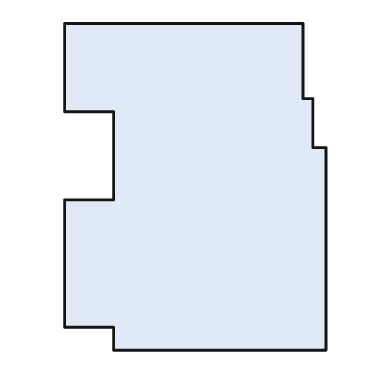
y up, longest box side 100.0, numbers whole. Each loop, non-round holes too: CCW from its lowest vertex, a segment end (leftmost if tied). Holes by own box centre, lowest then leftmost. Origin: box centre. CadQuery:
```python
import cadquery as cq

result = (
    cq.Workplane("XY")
    .moveTo(-25.0, -50.0)
    .lineTo(40.0, -50.0)
    .lineTo(40.0, 12.0)
    .lineTo(36.0, 12.0)
    .lineTo(36.0, 27.0)
    .lineTo(33.0, 27.0)
    .lineTo(33.0, 50.0)
    .lineTo(-40.0, 50.0)
    .lineTo(-40.0, 23.0)
    .lineTo(-25.0, 23.0)
    .lineTo(-25.0, -4.0)
    .lineTo(-40.0, -4.0)
    .lineTo(-40.0, -43.0)
    .lineTo(-25.0, -43.0)
    .close()
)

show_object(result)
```